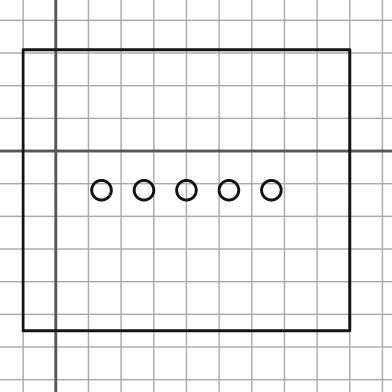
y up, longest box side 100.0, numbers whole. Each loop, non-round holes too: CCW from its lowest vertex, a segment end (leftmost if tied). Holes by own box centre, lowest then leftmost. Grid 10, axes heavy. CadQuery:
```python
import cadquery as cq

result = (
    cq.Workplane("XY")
    .moveTo(-10.0, -55.0)
    .lineTo(90.0, -55.0)
    .lineTo(90.0, 31.0)
    .lineTo(-10.0, 31.0)
    .close()
    .moveTo(14.0, -12.0)
    .circle(3.0)
    .moveTo(27.0, -12.0)
    .circle(3.0)
    .moveTo(40.0, -12.0)
    .circle(3.0)
    .moveTo(53.0, -12.0)
    .circle(3.0)
    .moveTo(66.0, -12.0)
    .circle(3.0)
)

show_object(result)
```